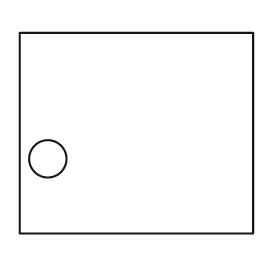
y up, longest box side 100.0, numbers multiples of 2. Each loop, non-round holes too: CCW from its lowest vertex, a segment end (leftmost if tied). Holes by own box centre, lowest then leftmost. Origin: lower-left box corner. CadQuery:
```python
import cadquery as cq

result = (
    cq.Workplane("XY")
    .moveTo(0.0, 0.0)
    .lineTo(100.0, 0.0)
    .lineTo(100.0, 86.0)
    .lineTo(0.0, 86.0)
    .close()
    .moveTo(12.0, 32.0)
    .circle(8.0)
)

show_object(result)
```